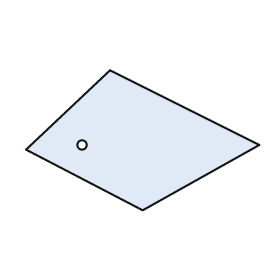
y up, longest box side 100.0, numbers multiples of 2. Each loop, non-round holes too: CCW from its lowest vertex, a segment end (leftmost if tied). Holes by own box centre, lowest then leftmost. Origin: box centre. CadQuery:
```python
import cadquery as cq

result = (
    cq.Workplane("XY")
    .moveTo(0.0, -30.0)
    .lineTo(50.0, -2.0)
    .lineTo(-14.0, 30.0)
    .lineTo(-50.0, -4.0)
    .close()
    .moveTo(-26.0, -2.0)
    .circle(2.0)
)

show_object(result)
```